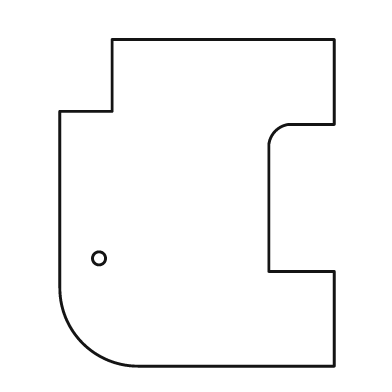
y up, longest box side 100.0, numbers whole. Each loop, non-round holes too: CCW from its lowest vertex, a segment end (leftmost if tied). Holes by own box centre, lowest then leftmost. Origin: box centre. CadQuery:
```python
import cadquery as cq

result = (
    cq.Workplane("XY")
    .moveTo(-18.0, -50.0)
    .lineTo(42.0, -50.0)
    .lineTo(42.0, -21.0)
    .lineTo(22.0, -21.0)
    .lineTo(22.0, 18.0)
    .threePointArc((24.0, 22.0), (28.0, 24.0))
    .lineTo(42.0, 24.0)
    .lineTo(42.0, 50.0)
    .lineTo(-26.0, 50.0)
    .lineTo(-26.0, 28.0)
    .lineTo(-42.0, 28.0)
    .lineTo(-42.0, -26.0)
    .threePointArc((-35.0, -43.0), (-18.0, -50.0))
    .close()
    .moveTo(-30.0, -17.0)
    .circle(2.0)
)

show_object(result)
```